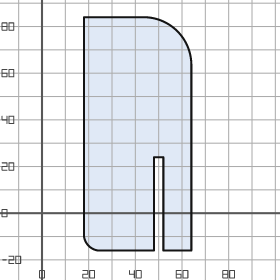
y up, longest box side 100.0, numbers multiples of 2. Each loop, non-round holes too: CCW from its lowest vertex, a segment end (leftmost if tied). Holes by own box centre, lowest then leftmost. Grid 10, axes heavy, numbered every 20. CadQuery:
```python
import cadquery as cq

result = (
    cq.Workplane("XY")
    .moveTo(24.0, -16.0)
    .lineTo(48.0, -16.0)
    .lineTo(48.0, 24.0)
    .lineTo(52.0, 24.0)
    .lineTo(52.0, -16.0)
    .lineTo(64.0, -16.0)
    .lineTo(64.0, 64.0)
    .threePointArc((58.0, 78.0), (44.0, 84.0))
    .lineTo(18.0, 84.0)
    .lineTo(18.0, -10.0)
    .threePointArc((20.0, -14.0), (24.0, -16.0))
    .close()
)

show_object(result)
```